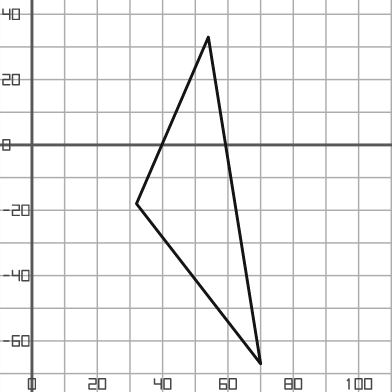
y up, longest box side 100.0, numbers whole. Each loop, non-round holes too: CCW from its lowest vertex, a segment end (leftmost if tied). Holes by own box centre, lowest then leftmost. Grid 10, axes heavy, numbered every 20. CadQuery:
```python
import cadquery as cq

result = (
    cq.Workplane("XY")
    .moveTo(70.0, -67.0)
    .lineTo(54.0, 33.0)
    .lineTo(32.0, -18.0)
    .close()
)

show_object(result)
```